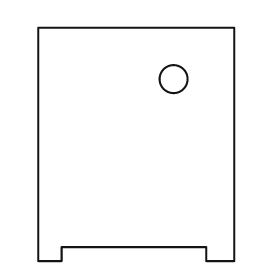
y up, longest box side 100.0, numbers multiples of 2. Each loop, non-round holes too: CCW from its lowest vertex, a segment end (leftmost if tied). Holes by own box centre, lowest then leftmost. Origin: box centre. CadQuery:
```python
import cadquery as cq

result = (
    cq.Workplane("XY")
    .moveTo(-42.0, -50.0)
    .lineTo(-32.0, -50.0)
    .lineTo(-32.0, -44.0)
    .lineTo(30.0, -44.0)
    .lineTo(30.0, -50.0)
    .lineTo(42.0, -50.0)
    .lineTo(42.0, 50.0)
    .lineTo(-42.0, 50.0)
    .close()
    .moveTo(16.0, 28.0)
    .circle(6.0)
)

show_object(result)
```